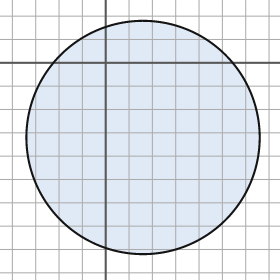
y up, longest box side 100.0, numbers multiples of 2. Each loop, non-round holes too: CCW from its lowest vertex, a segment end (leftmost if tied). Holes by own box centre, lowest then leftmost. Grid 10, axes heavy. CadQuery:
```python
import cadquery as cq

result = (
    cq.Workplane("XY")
    .moveTo(16.0, -32.0)
    .circle(50.0)
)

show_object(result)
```